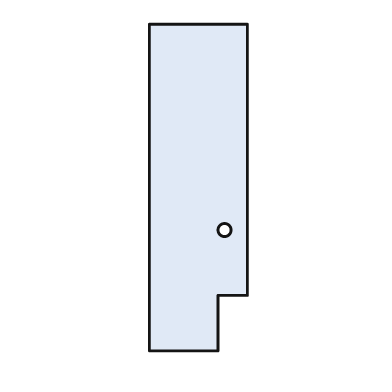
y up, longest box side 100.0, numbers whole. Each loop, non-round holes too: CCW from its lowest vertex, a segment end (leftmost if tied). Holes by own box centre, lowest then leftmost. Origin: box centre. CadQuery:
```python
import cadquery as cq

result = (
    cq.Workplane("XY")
    .moveTo(-15.0, -50.0)
    .lineTo(6.0, -50.0)
    .lineTo(6.0, -33.0)
    .lineTo(15.0, -33.0)
    .lineTo(15.0, 50.0)
    .lineTo(-15.0, 50.0)
    .close()
    .moveTo(8.0, -13.0)
    .circle(2.0)
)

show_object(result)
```